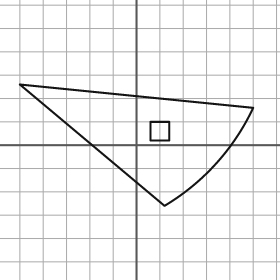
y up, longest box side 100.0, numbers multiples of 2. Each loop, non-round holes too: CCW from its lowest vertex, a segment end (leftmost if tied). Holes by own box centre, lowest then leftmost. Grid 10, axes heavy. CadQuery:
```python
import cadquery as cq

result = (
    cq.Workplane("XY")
    .moveTo(12.0, -26.0)
    .threePointArc((34.0, -8.0), (50.0, 16.0))
    .lineTo(-50.0, 26.0)
    .close()
    .moveTo(6.0, 2.0)
    .lineTo(14.0, 2.0)
    .lineTo(14.0, 10.0)
    .lineTo(6.0, 10.0)
    .close()
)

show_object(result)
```